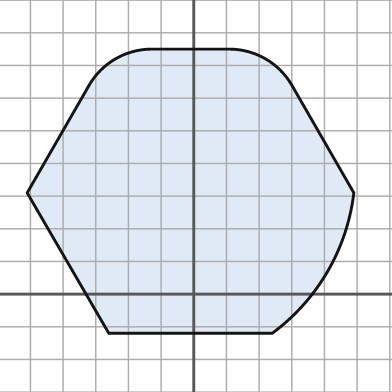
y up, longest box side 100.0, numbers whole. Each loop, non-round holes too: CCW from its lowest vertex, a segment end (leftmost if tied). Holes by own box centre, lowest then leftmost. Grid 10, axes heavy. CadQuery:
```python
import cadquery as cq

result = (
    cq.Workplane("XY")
    .moveTo(-26.0, -12.0)
    .lineTo(24.0, -12.0)
    .threePointArc((41.0, 7.0), (49.0, 31.0))
    .lineTo(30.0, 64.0)
    .threePointArc((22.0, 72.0), (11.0, 75.0))
    .lineTo(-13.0, 75.0)
    .threePointArc((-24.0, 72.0), (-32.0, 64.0))
    .lineTo(-51.0, 31.0)
    .close()
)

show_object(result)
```